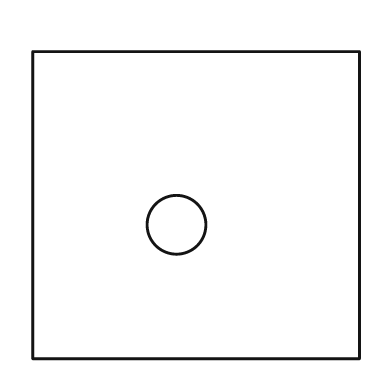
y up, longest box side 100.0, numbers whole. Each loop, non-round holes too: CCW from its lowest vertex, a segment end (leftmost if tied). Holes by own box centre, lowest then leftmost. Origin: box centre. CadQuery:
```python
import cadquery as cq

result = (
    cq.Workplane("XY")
    .moveTo(-50.0, -47.0)
    .lineTo(50.0, -47.0)
    .lineTo(50.0, 47.0)
    .lineTo(-50.0, 47.0)
    .close()
    .moveTo(-6.0, -6.0)
    .circle(9.0)
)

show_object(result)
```